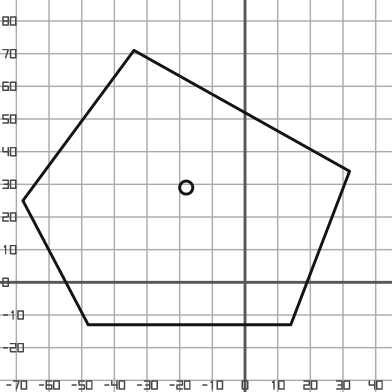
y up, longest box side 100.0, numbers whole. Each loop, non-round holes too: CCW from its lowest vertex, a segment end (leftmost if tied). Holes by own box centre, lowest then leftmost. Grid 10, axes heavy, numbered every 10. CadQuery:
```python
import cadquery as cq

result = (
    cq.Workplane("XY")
    .moveTo(-48.0, -13.0)
    .lineTo(14.0, -13.0)
    .lineTo(32.0, 34.0)
    .lineTo(-34.0, 71.0)
    .lineTo(-68.0, 25.0)
    .close()
    .moveTo(-18.0, 29.0)
    .circle(2.0)
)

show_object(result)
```